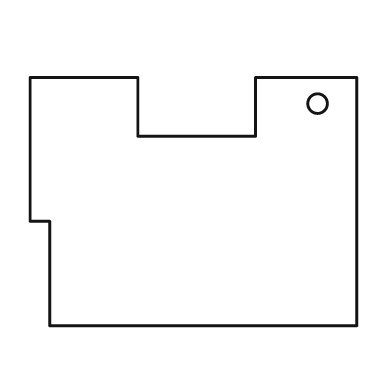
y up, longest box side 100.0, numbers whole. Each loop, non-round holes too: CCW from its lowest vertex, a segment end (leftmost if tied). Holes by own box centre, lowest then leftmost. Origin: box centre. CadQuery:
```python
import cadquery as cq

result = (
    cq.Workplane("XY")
    .moveTo(-44.0, -38.0)
    .lineTo(50.0, -38.0)
    .lineTo(50.0, 38.0)
    .lineTo(19.0, 38.0)
    .lineTo(19.0, 20.0)
    .lineTo(-17.0, 20.0)
    .lineTo(-17.0, 38.0)
    .lineTo(-50.0, 38.0)
    .lineTo(-50.0, -6.0)
    .lineTo(-44.0, -6.0)
    .close()
    .moveTo(38.0, 30.0)
    .circle(3.0)
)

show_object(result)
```